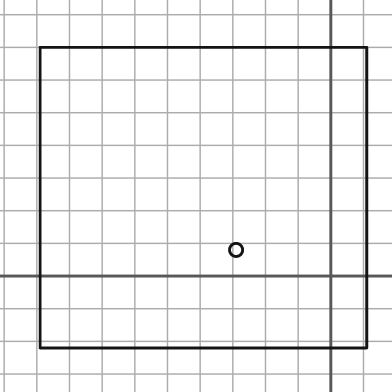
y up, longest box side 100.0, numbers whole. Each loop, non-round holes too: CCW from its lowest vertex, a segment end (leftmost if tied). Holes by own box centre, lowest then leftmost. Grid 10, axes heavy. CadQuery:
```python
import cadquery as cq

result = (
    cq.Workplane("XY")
    .moveTo(-89.0, -22.0)
    .lineTo(11.0, -22.0)
    .lineTo(11.0, 70.0)
    .lineTo(-89.0, 70.0)
    .close()
    .moveTo(-29.0, 8.0)
    .circle(2.0)
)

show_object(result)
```